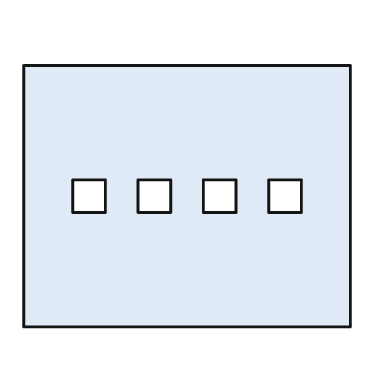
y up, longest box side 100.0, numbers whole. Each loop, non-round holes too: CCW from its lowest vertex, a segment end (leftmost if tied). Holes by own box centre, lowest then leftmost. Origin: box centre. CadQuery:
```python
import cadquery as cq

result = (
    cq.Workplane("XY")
    .moveTo(-50.0, -40.0)
    .lineTo(50.0, -40.0)
    .lineTo(50.0, 40.0)
    .lineTo(-50.0, 40.0)
    .close()
    .moveTo(-35.0, -5.0)
    .lineTo(-25.0, -5.0)
    .lineTo(-25.0, 5.0)
    .lineTo(-35.0, 5.0)
    .close()
    .moveTo(-15.0, -5.0)
    .lineTo(-5.0, -5.0)
    .lineTo(-5.0, 5.0)
    .lineTo(-15.0, 5.0)
    .close()
    .moveTo(5.0, -5.0)
    .lineTo(15.0, -5.0)
    .lineTo(15.0, 5.0)
    .lineTo(5.0, 5.0)
    .close()
    .moveTo(25.0, -5.0)
    .lineTo(35.0, -5.0)
    .lineTo(35.0, 5.0)
    .lineTo(25.0, 5.0)
    .close()
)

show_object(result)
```